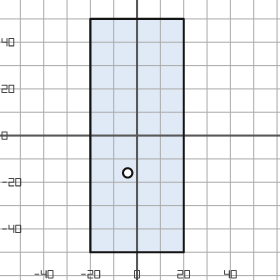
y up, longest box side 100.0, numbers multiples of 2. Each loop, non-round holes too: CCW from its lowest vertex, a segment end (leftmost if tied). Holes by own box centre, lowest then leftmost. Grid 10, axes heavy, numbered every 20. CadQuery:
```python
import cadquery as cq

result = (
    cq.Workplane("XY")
    .moveTo(-20.0, -50.0)
    .lineTo(20.0, -50.0)
    .lineTo(20.0, 50.0)
    .lineTo(-20.0, 50.0)
    .close()
    .moveTo(-4.0, -16.0)
    .circle(2.0)
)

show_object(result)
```